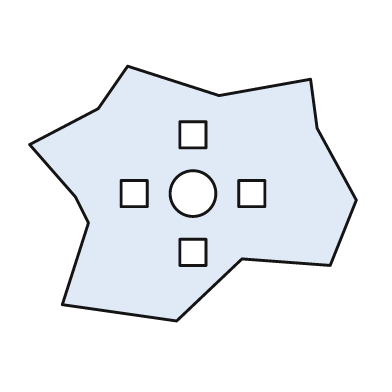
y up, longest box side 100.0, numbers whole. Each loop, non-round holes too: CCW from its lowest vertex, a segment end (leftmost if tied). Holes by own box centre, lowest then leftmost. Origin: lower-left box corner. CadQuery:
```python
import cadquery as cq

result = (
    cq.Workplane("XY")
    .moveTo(45.0, 0.0)
    .lineTo(65.0, 19.0)
    .lineTo(92.0, 17.0)
    .lineTo(100.0, 37.0)
    .lineTo(88.0, 59.0)
    .lineTo(86.0, 74.0)
    .lineTo(58.0, 69.0)
    .lineTo(30.0, 78.0)
    .lineTo(21.0, 65.0)
    .lineTo(0.0, 54.0)
    .lineTo(14.0, 38.0)
    .lineTo(18.0, 30.0)
    .lineTo(10.0, 5.0)
    .close()
    .moveTo(46.0, 17.0)
    .lineTo(54.0, 17.0)
    .lineTo(54.0, 25.0)
    .lineTo(46.0, 25.0)
    .close()
    .moveTo(28.0, 35.0)
    .lineTo(36.0, 35.0)
    .lineTo(36.0, 43.0)
    .lineTo(28.0, 43.0)
    .close()
    .moveTo(50.0, 39.0)
    .circle(7.0)
    .moveTo(64.0, 35.0)
    .lineTo(72.0, 35.0)
    .lineTo(72.0, 43.0)
    .lineTo(64.0, 43.0)
    .close()
    .moveTo(46.0, 53.0)
    .lineTo(54.0, 53.0)
    .lineTo(54.0, 61.0)
    .lineTo(46.0, 61.0)
    .close()
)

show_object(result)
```